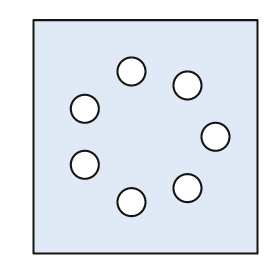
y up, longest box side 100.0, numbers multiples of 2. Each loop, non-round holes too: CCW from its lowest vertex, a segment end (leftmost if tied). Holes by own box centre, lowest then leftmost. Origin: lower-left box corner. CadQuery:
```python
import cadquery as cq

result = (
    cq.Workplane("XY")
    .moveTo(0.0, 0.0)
    .lineTo(96.0, 0.0)
    .lineTo(96.0, 100.0)
    .lineTo(0.0, 100.0)
    .close()
    .moveTo(42.0, 22.0)
    .circle(6.0)
    .moveTo(66.0, 28.0)
    .circle(6.0)
    .moveTo(22.0, 38.0)
    .circle(6.0)
    .moveTo(78.0, 50.0)
    .circle(6.0)
    .moveTo(22.0, 62.0)
    .circle(6.0)
    .moveTo(66.0, 72.0)
    .circle(6.0)
    .moveTo(42.0, 78.0)
    .circle(6.0)
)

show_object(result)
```